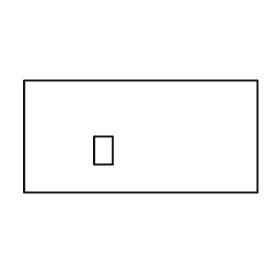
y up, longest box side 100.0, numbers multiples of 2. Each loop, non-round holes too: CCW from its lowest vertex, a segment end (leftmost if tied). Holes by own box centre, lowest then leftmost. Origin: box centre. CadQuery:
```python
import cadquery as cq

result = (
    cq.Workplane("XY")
    .moveTo(-50.0, -24.0)
    .lineTo(50.0, -24.0)
    .lineTo(50.0, 24.0)
    .lineTo(-50.0, 24.0)
    .close()
    .moveTo(-20.0, -12.0)
    .lineTo(-12.0, -12.0)
    .lineTo(-12.0, 0.0)
    .lineTo(-20.0, 0.0)
    .close()
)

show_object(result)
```